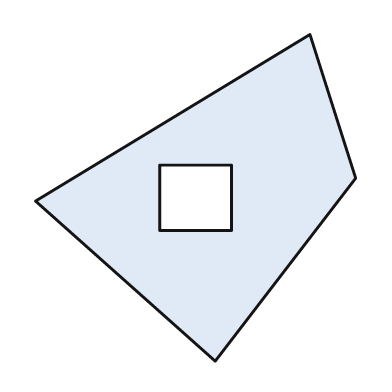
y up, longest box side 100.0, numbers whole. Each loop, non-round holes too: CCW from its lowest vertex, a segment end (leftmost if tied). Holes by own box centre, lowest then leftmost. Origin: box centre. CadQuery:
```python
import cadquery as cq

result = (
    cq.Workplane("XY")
    .moveTo(6.0, -50.0)
    .lineTo(49.0, 6.0)
    .lineTo(35.0, 50.0)
    .lineTo(-49.0, -1.0)
    .close()
    .moveTo(-11.0, -10.0)
    .lineTo(11.0, -10.0)
    .lineTo(11.0, 10.0)
    .lineTo(-11.0, 10.0)
    .close()
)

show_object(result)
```